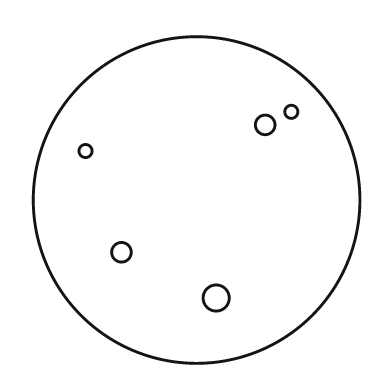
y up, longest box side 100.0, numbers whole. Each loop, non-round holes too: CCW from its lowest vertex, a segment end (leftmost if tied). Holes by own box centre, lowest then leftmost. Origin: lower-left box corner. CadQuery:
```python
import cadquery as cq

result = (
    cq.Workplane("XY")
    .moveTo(50.0, 50.0)
    .circle(50.0)
    .moveTo(56.0, 20.0)
    .circle(4.0)
    .moveTo(27.0, 34.0)
    .circle(3.0)
    .moveTo(16.0, 65.0)
    .circle(2.0)
    .moveTo(71.0, 73.0)
    .circle(3.0)
    .moveTo(79.0, 77.0)
    .circle(2.0)
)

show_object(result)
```